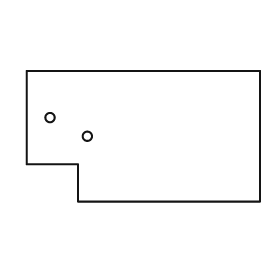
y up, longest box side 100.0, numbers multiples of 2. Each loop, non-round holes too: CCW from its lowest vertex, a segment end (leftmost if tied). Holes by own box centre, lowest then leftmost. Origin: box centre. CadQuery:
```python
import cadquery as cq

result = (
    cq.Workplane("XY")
    .moveTo(-28.0, -28.0)
    .lineTo(50.0, -28.0)
    .lineTo(50.0, 28.0)
    .lineTo(-50.0, 28.0)
    .lineTo(-50.0, -12.0)
    .lineTo(-28.0, -12.0)
    .close()
    .moveTo(-24.0, 0.0)
    .circle(2.0)
    .moveTo(-40.0, 8.0)
    .circle(2.0)
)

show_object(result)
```